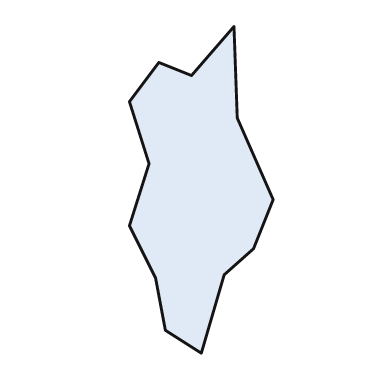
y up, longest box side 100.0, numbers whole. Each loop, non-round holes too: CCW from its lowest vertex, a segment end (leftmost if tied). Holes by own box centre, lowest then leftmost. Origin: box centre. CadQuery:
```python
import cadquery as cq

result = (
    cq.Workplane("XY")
    .moveTo(0.0, -50.0)
    .lineTo(7.0, -26.0)
    .lineTo(16.0, -18.0)
    .lineTo(22.0, -3.0)
    .lineTo(11.0, 22.0)
    .lineTo(10.0, 50.0)
    .lineTo(-3.0, 35.0)
    .lineTo(-13.0, 39.0)
    .lineTo(-22.0, 27.0)
    .lineTo(-16.0, 8.0)
    .lineTo(-22.0, -11.0)
    .lineTo(-14.0, -27.0)
    .lineTo(-11.0, -43.0)
    .close()
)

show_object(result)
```